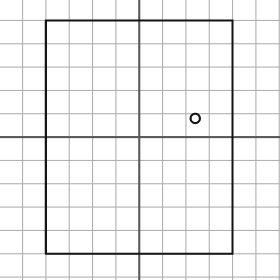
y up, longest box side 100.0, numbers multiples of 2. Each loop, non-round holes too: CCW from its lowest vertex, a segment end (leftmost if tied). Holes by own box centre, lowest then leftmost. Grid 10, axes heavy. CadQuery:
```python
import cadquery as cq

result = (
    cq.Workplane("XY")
    .moveTo(-40.0, -50.0)
    .lineTo(40.0, -50.0)
    .lineTo(40.0, 50.0)
    .lineTo(-40.0, 50.0)
    .close()
    .moveTo(24.0, 8.0)
    .circle(2.0)
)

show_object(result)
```